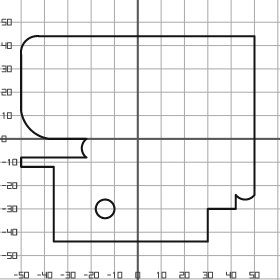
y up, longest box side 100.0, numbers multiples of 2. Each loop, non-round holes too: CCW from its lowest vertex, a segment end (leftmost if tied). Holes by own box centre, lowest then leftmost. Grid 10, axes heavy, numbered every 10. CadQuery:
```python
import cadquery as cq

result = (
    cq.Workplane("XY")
    .moveTo(-36.0, -44.0)
    .lineTo(30.0, -44.0)
    .lineTo(30.0, -30.0)
    .lineTo(42.0, -30.0)
    .lineTo(42.0, -24.0)
    .threePointArc((46.0, -26.0), (50.0, -24.0))
    .lineTo(50.0, 44.0)
    .lineTo(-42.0, 44.0)
    .threePointArc((-48.0, 42.0), (-50.0, 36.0))
    .lineTo(-50.0, 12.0)
    .threePointArc((-46.0, 4.0), (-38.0, 0.0))
    .lineTo(-22.0, 0.0)
    .threePointArc((-24.0, -4.0), (-22.0, -8.0))
    .lineTo(-50.0, -8.0)
    .lineTo(-50.0, -12.0)
    .lineTo(-36.0, -12.0)
    .close()
    .moveTo(-14.0, -30.0)
    .circle(4.0)
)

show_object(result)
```